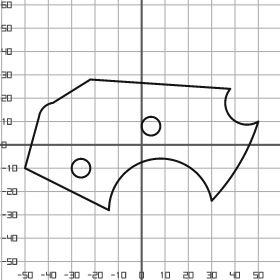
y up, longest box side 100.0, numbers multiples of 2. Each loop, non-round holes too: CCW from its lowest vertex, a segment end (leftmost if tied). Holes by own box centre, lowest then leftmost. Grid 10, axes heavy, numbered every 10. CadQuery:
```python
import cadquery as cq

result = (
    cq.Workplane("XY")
    .moveTo(-14.0, -28.0)
    .threePointArc((6.0, -6.0), (30.0, -24.0))
    .threePointArc((42.0, -8.0), (50.0, 10.0))
    .threePointArc((38.0, 12.0), (38.0, 24.0))
    .lineTo(-22.0, 28.0)
    .lineTo(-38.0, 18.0)
    .threePointArc((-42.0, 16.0), (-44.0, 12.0))
    .lineTo(-50.0, -10.0)
    .close()
    .moveTo(-26.0, -10.0)
    .circle(4.0)
    .moveTo(4.0, 8.0)
    .circle(4.0)
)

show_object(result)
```